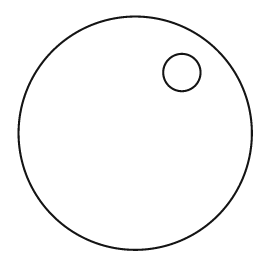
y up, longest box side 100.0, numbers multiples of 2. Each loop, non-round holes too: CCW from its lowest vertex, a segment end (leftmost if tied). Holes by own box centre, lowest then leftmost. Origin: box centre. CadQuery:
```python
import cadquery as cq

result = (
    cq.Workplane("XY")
    .moveTo(0.0, 0.0)
    .circle(50.0)
    .moveTo(20.0, 26.0)
    .circle(8.0)
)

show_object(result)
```